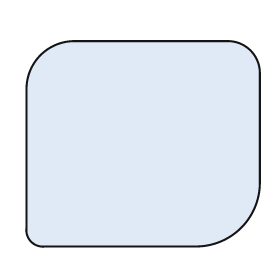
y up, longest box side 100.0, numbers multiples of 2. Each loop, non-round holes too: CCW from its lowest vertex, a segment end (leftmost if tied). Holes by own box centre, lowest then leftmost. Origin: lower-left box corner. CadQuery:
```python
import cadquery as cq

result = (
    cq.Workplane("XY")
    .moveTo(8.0, 0.0)
    .lineTo(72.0, 0.0)
    .threePointArc((92.0, 8.0), (100.0, 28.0))
    .lineTo(100.0, 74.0)
    .threePointArc((96.0, 84.0), (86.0, 88.0))
    .lineTo(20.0, 88.0)
    .threePointArc((6.0, 82.0), (0.0, 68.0))
    .lineTo(0.0, 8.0)
    .threePointArc((2.0, 2.0), (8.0, 0.0))
    .close()
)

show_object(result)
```